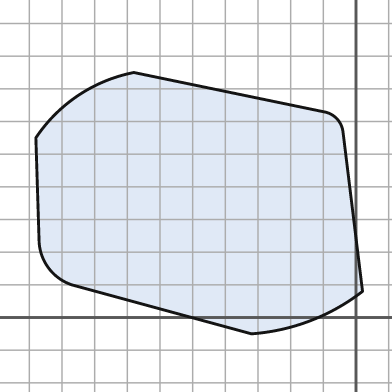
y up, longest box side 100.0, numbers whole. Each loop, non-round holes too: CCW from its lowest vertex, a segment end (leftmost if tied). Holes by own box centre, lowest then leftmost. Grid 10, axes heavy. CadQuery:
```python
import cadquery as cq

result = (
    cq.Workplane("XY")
    .moveTo(-32.0, -5.0)
    .threePointArc((-14.0, -1.0), (2.0, 8.0))
    .lineTo(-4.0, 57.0)
    .threePointArc((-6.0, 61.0), (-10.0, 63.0))
    .lineTo(-68.0, 75.0)
    .threePointArc((-85.0, 68.0), (-98.0, 55.0))
    .lineTo(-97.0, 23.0)
    .threePointArc((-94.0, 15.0), (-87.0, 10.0))
    .close()
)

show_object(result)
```